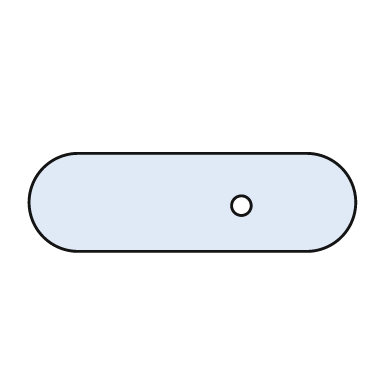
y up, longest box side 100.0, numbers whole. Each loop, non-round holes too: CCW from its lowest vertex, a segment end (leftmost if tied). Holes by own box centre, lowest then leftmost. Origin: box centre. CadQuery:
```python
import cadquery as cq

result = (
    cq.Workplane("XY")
    .moveTo(-35.0, -15.0)
    .lineTo(35.0, -15.0)
    .threePointArc((50.0, 0.0), (35.0, 15.0))
    .lineTo(-35.0, 15.0)
    .threePointArc((-50.0, 0.0), (-35.0, -15.0))
    .close()
    .moveTo(15.0, -1.0)
    .circle(3.0)
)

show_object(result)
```